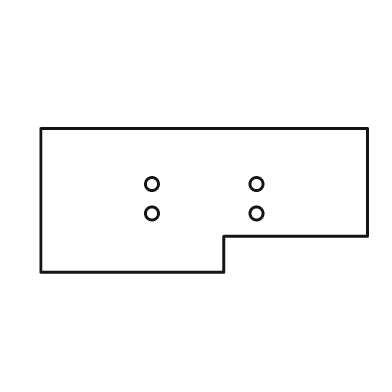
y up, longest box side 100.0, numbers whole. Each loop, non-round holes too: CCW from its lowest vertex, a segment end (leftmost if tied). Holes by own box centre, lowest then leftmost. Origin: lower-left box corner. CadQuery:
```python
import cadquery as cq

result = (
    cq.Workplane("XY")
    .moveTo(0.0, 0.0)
    .lineTo(56.0, 0.0)
    .lineTo(56.0, 11.0)
    .lineTo(100.0, 11.0)
    .lineTo(100.0, 44.0)
    .lineTo(0.0, 44.0)
    .close()
    .moveTo(34.0, 18.0)
    .circle(2.0)
    .moveTo(66.0, 18.0)
    .circle(2.0)
    .moveTo(34.0, 27.0)
    .circle(2.0)
    .moveTo(66.0, 27.0)
    .circle(2.0)
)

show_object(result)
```